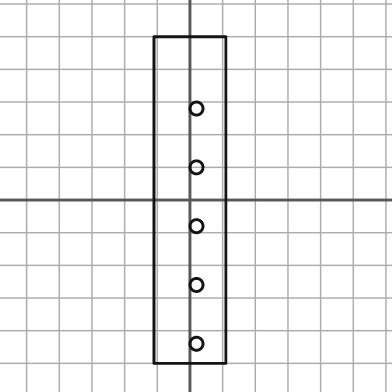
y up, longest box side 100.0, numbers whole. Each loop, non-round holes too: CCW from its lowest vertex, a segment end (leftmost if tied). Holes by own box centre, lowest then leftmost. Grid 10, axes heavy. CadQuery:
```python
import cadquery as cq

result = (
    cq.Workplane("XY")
    .moveTo(-11.0, -50.0)
    .lineTo(11.0, -50.0)
    .lineTo(11.0, 50.0)
    .lineTo(-11.0, 50.0)
    .close()
    .moveTo(2.0, -44.0)
    .circle(2.0)
    .moveTo(2.0, -26.0)
    .circle(2.0)
    .moveTo(2.0, -8.0)
    .circle(2.0)
    .moveTo(2.0, 10.0)
    .circle(2.0)
    .moveTo(2.0, 28.0)
    .circle(2.0)
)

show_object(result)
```